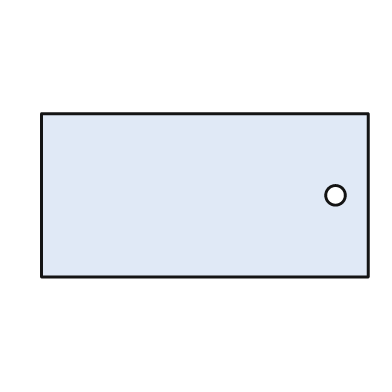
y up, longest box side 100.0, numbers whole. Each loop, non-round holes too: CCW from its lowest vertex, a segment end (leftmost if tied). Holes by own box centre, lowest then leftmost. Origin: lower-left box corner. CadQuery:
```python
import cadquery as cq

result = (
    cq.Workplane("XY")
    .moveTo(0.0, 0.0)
    .lineTo(100.0, 0.0)
    .lineTo(100.0, 50.0)
    .lineTo(0.0, 50.0)
    .close()
    .moveTo(90.0, 25.0)
    .circle(3.0)
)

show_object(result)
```